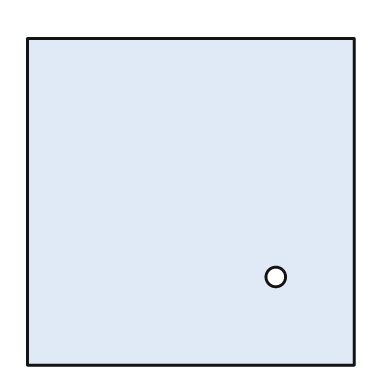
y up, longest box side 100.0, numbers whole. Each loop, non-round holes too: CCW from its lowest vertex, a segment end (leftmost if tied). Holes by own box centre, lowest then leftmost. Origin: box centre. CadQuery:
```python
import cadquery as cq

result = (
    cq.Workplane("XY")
    .moveTo(-50.0, -50.0)
    .lineTo(50.0, -50.0)
    .lineTo(50.0, 50.0)
    .lineTo(-50.0, 50.0)
    .close()
    .moveTo(26.0, -23.0)
    .circle(3.0)
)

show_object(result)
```